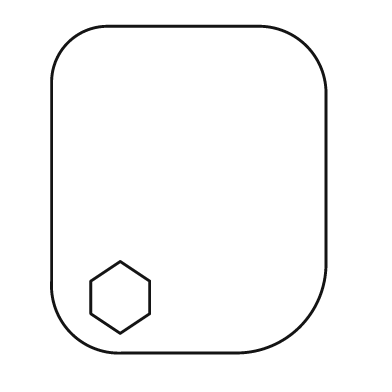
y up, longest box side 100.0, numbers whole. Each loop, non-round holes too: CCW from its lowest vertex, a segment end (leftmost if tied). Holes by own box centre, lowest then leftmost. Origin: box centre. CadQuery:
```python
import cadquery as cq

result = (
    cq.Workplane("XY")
    .moveTo(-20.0, -50.0)
    .lineTo(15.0, -50.0)
    .threePointArc((34.0, -42.0), (42.0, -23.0))
    .lineTo(42.0, 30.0)
    .threePointArc((36.0, 44.0), (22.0, 50.0))
    .lineTo(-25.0, 50.0)
    .threePointArc((-37.0, 45.0), (-42.0, 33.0))
    .lineTo(-42.0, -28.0)
    .threePointArc((-36.0, -44.0), (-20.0, -50.0))
    .close()
    .moveTo(-21.0, -44.0)
    .lineTo(-12.0, -38.0)
    .lineTo(-12.0, -28.0)
    .lineTo(-21.0, -22.0)
    .lineTo(-30.0, -28.0)
    .lineTo(-30.0, -38.0)
    .close()
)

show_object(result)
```